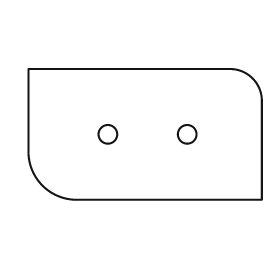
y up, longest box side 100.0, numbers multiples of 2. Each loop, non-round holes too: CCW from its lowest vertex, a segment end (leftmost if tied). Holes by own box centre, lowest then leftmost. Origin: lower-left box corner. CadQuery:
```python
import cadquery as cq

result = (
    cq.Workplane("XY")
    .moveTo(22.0, 0.0)
    .lineTo(100.0, 0.0)
    .lineTo(100.0, 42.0)
    .threePointArc((96.0, 52.0), (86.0, 56.0))
    .lineTo(0.0, 56.0)
    .lineTo(0.0, 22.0)
    .threePointArc((6.0, 6.0), (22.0, 0.0))
    .close()
    .moveTo(34.0, 28.0)
    .circle(4.0)
    .moveTo(68.0, 28.0)
    .circle(4.0)
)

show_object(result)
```